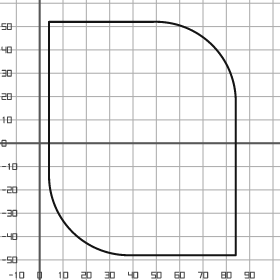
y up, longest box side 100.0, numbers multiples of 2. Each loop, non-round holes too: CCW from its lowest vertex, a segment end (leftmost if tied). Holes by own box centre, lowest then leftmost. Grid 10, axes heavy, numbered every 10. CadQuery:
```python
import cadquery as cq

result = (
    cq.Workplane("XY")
    .moveTo(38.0, -48.0)
    .lineTo(84.0, -48.0)
    .lineTo(84.0, 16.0)
    .threePointArc((74.0, 42.0), (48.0, 52.0))
    .lineTo(4.0, 52.0)
    .lineTo(4.0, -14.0)
    .threePointArc((14.0, -38.0), (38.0, -48.0))
    .close()
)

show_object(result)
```